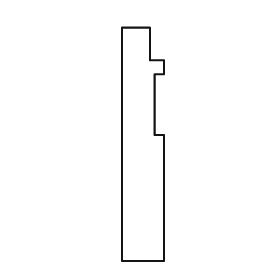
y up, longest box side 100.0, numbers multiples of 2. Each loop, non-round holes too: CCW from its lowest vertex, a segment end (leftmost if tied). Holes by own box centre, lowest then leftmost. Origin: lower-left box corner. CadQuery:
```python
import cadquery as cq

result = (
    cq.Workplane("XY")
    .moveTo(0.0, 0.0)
    .lineTo(18.0, 0.0)
    .lineTo(18.0, 54.0)
    .lineTo(14.0, 54.0)
    .lineTo(14.0, 80.0)
    .lineTo(18.0, 80.0)
    .lineTo(18.0, 86.0)
    .lineTo(12.0, 86.0)
    .lineTo(12.0, 100.0)
    .lineTo(0.0, 100.0)
    .close()
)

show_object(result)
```